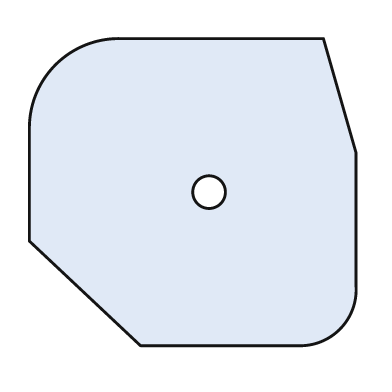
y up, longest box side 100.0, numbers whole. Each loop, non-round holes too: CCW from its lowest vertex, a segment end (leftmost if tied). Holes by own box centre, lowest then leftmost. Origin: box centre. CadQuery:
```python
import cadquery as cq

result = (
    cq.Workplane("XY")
    .moveTo(-16.0, -47.0)
    .lineTo(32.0, -47.0)
    .threePointArc((45.0, -42.0), (50.0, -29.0))
    .lineTo(50.0, 12.0)
    .lineTo(40.0, 47.0)
    .lineTo(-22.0, 47.0)
    .threePointArc((-42.0, 39.0), (-50.0, 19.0))
    .lineTo(-50.0, -15.0)
    .close()
    .moveTo(5.0, 0.0)
    .circle(5.0)
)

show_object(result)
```